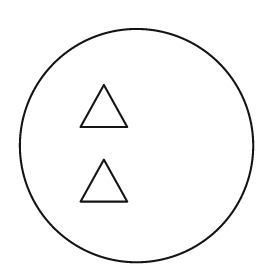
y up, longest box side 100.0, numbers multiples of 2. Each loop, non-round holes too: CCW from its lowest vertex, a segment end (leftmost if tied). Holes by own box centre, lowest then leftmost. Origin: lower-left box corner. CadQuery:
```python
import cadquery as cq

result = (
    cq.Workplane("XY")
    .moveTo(50.0, 50.0)
    .circle(50.0)
    .moveTo(26.0, 26.0)
    .lineTo(46.0, 26.0)
    .lineTo(36.0, 44.0)
    .close()
    .moveTo(26.0, 58.0)
    .lineTo(46.0, 58.0)
    .lineTo(36.0, 76.0)
    .close()
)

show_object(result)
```